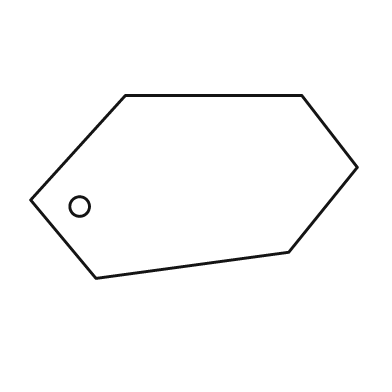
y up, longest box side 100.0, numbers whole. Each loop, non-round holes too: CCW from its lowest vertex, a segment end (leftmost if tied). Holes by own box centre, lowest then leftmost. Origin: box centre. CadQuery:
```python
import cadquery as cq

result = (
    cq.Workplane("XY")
    .moveTo(-30.0, -28.0)
    .lineTo(29.0, -20.0)
    .lineTo(50.0, 6.0)
    .lineTo(33.0, 28.0)
    .lineTo(-21.0, 28.0)
    .lineTo(-50.0, -4.0)
    .close()
    .moveTo(-35.0, -6.0)
    .circle(3.0)
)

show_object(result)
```